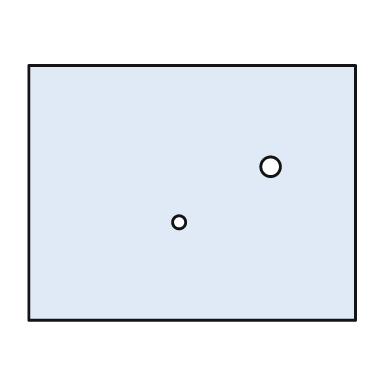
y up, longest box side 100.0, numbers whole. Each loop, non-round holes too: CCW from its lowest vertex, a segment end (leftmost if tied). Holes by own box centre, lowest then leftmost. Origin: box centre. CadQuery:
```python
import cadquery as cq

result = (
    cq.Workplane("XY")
    .moveTo(-50.0, -39.0)
    .lineTo(50.0, -39.0)
    .lineTo(50.0, 39.0)
    .lineTo(-50.0, 39.0)
    .close()
    .moveTo(-4.0, -9.0)
    .circle(2.0)
    .moveTo(24.0, 8.0)
    .circle(3.0)
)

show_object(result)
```